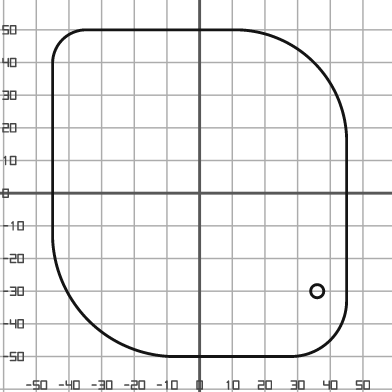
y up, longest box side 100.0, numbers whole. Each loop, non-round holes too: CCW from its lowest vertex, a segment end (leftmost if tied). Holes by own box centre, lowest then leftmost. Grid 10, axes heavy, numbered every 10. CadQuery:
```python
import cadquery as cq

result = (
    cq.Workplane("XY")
    .moveTo(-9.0, -50.0)
    .lineTo(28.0, -50.0)
    .threePointArc((40.0, -45.0), (45.0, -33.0))
    .lineTo(45.0, 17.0)
    .threePointArc((35.0, 40.0), (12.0, 50.0))
    .lineTo(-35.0, 50.0)
    .threePointArc((-42.0, 47.0), (-45.0, 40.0))
    .lineTo(-45.0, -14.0)
    .threePointArc((-34.0, -39.0), (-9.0, -50.0))
    .close()
    .moveTo(36.0, -30.0)
    .circle(2.0)
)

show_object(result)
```